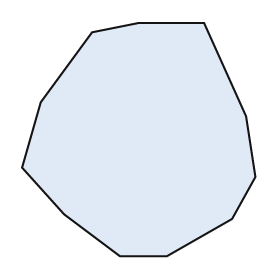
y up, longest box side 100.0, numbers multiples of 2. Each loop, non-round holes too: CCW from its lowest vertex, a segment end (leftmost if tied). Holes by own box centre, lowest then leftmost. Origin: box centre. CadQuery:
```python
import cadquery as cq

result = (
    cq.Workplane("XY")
    .moveTo(-8.0, -50.0)
    .lineTo(12.0, -50.0)
    .lineTo(40.0, -34.0)
    .lineTo(50.0, -16.0)
    .lineTo(46.0, 10.0)
    .lineTo(28.0, 50.0)
    .lineTo(0.0, 50.0)
    .lineTo(-20.0, 46.0)
    .lineTo(-42.0, 16.0)
    .lineTo(-50.0, -12.0)
    .lineTo(-32.0, -32.0)
    .close()
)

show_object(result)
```